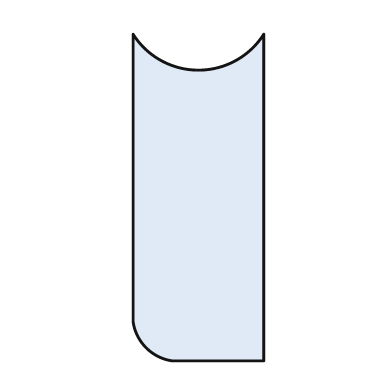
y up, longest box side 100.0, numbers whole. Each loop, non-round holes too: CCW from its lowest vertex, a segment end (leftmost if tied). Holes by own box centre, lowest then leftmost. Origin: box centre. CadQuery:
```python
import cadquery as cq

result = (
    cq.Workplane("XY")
    .moveTo(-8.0, -50.0)
    .lineTo(20.0, -50.0)
    .lineTo(20.0, 50.0)
    .threePointArc((0.0, 39.0), (-20.0, 50.0))
    .lineTo(-20.0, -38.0)
    .threePointArc((-16.0, -46.0), (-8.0, -50.0))
    .close()
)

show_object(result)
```